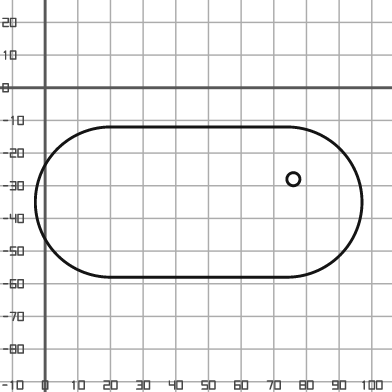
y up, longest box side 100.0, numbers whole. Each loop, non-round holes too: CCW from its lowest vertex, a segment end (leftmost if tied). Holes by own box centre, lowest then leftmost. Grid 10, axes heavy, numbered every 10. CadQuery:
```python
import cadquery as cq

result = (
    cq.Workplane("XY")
    .moveTo(20.0, -58.0)
    .lineTo(74.0, -58.0)
    .threePointArc((97.0, -35.0), (74.0, -12.0))
    .lineTo(20.0, -12.0)
    .threePointArc((-3.0, -35.0), (20.0, -58.0))
    .close()
    .moveTo(76.0, -28.0)
    .circle(2.0)
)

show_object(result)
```